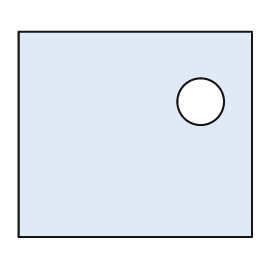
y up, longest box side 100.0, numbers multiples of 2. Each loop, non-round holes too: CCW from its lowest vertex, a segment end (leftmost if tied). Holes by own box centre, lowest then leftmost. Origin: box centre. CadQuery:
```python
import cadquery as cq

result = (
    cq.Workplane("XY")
    .moveTo(-50.0, -44.0)
    .lineTo(50.0, -44.0)
    .lineTo(50.0, 44.0)
    .lineTo(-50.0, 44.0)
    .close()
    .moveTo(28.0, 14.0)
    .circle(10.0)
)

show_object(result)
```